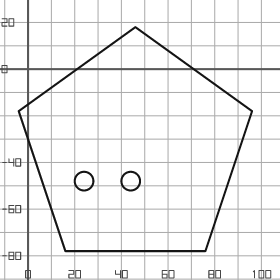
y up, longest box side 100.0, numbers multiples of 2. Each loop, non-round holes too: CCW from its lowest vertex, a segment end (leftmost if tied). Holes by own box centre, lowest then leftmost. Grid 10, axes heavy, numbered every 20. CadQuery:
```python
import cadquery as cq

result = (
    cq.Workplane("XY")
    .moveTo(16.0, -78.0)
    .lineTo(76.0, -78.0)
    .lineTo(96.0, -18.0)
    .lineTo(46.0, 18.0)
    .lineTo(-4.0, -18.0)
    .close()
    .moveTo(24.0, -48.0)
    .circle(4.0)
    .moveTo(44.0, -48.0)
    .circle(4.0)
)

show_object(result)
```